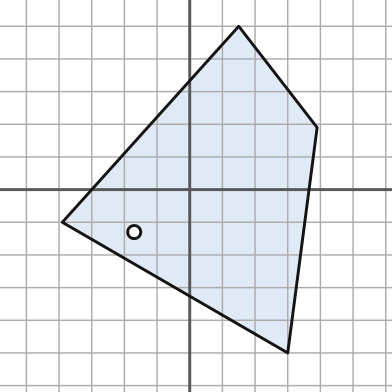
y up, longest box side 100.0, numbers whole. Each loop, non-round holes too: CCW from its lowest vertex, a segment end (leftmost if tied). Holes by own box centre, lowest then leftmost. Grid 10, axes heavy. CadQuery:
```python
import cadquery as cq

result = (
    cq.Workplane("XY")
    .moveTo(30.0, -50.0)
    .lineTo(39.0, 19.0)
    .lineTo(15.0, 50.0)
    .lineTo(-39.0, -10.0)
    .close()
    .moveTo(-17.0, -13.0)
    .circle(2.0)
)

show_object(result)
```